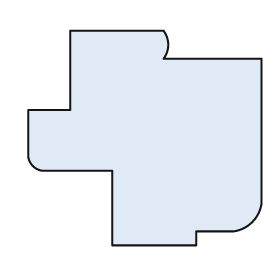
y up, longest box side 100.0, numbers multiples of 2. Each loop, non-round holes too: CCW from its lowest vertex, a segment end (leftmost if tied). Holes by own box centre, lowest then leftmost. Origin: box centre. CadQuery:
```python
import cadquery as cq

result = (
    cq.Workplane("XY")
    .moveTo(-14.0, -46.0)
    .lineTo(22.0, -46.0)
    .lineTo(22.0, -40.0)
    .lineTo(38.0, -40.0)
    .threePointArc((46.0, -36.0), (50.0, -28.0))
    .lineTo(50.0, 34.0)
    .lineTo(8.0, 34.0)
    .threePointArc((10.0, 40.0), (8.0, 46.0))
    .lineTo(-32.0, 46.0)
    .lineTo(-32.0, 12.0)
    .lineTo(-50.0, 12.0)
    .lineTo(-50.0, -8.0)
    .threePointArc((-48.0, -12.0), (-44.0, -14.0))
    .lineTo(-14.0, -14.0)
    .close()
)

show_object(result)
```